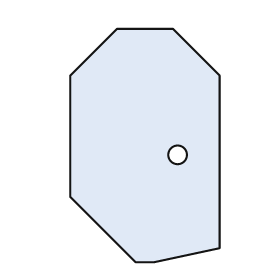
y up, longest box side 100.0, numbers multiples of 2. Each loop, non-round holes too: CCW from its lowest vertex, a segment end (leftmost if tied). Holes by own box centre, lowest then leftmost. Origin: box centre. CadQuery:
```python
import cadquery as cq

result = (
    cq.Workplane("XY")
    .moveTo(-4.0, -50.0)
    .lineTo(4.0, -50.0)
    .lineTo(32.0, -44.0)
    .lineTo(32.0, 30.0)
    .lineTo(12.0, 50.0)
    .lineTo(-12.0, 50.0)
    .lineTo(-32.0, 30.0)
    .lineTo(-32.0, -22.0)
    .close()
    .moveTo(14.0, -4.0)
    .circle(4.0)
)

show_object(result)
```